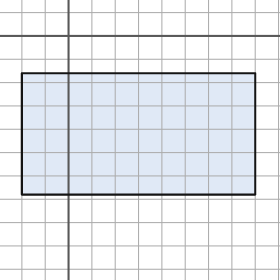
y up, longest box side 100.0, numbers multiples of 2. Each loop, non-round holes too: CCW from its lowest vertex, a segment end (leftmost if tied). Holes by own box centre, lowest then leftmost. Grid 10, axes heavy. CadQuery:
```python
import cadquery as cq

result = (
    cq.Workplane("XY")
    .moveTo(-20.0, -68.0)
    .lineTo(80.0, -68.0)
    .lineTo(80.0, -16.0)
    .lineTo(-20.0, -16.0)
    .close()
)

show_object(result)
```